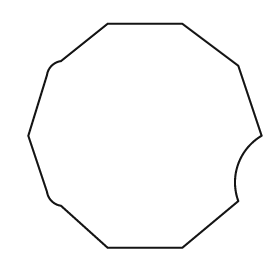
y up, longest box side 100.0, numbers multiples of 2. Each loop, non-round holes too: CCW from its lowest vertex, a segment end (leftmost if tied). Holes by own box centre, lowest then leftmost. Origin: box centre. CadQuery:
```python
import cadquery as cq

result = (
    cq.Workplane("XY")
    .moveTo(-16.0, -48.0)
    .lineTo(16.0, -48.0)
    .lineTo(40.0, -28.0)
    .threePointArc((40.0, -12.0), (50.0, 0.0))
    .lineTo(40.0, 30.0)
    .lineTo(16.0, 48.0)
    .lineTo(-16.0, 48.0)
    .lineTo(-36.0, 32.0)
    .threePointArc((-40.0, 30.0), (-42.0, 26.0))
    .lineTo(-50.0, 0.0)
    .lineTo(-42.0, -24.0)
    .threePointArc((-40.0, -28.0), (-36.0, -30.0))
    .close()
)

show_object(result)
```